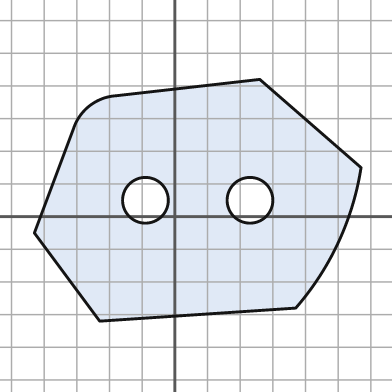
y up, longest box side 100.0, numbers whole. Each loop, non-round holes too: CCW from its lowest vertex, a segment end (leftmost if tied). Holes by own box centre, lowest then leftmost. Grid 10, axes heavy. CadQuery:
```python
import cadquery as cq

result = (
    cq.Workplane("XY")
    .moveTo(-23.0, -32.0)
    .lineTo(37.0, -28.0)
    .threePointArc((50.0, -8.0), (57.0, 15.0))
    .lineTo(26.0, 42.0)
    .lineTo(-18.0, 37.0)
    .threePointArc((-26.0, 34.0), (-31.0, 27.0))
    .lineTo(-43.0, -5.0)
    .close()
    .moveTo(-9.0, 5.0)
    .circle(7.0)
    .moveTo(23.0, 5.0)
    .circle(7.0)
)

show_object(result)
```